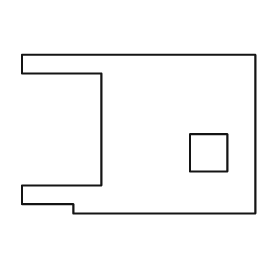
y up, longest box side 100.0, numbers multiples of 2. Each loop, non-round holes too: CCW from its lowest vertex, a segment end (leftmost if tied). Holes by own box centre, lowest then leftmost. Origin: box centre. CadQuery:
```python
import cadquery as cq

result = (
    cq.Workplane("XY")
    .moveTo(-28.0, -34.0)
    .lineTo(50.0, -34.0)
    .lineTo(50.0, 34.0)
    .lineTo(-50.0, 34.0)
    .lineTo(-50.0, 26.0)
    .lineTo(-16.0, 26.0)
    .lineTo(-16.0, -22.0)
    .lineTo(-50.0, -22.0)
    .lineTo(-50.0, -30.0)
    .lineTo(-28.0, -30.0)
    .close()
    .moveTo(22.0, -16.0)
    .lineTo(38.0, -16.0)
    .lineTo(38.0, 0.0)
    .lineTo(22.0, 0.0)
    .close()
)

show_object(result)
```